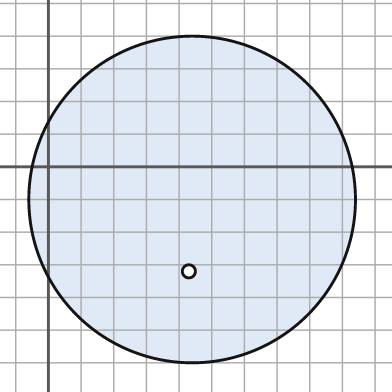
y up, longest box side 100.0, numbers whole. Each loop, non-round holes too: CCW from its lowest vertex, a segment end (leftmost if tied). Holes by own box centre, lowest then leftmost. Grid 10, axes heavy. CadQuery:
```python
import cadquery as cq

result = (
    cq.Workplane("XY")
    .moveTo(44.0, -10.0)
    .circle(50.0)
    .moveTo(43.0, -32.0)
    .circle(2.0)
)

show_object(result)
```